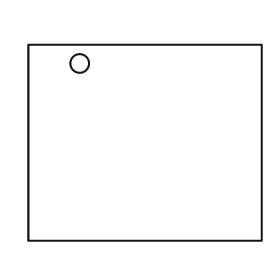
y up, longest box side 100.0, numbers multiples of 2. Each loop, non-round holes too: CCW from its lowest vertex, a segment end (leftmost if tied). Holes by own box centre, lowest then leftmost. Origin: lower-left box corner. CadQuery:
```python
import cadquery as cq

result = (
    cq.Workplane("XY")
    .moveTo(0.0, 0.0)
    .lineTo(100.0, 0.0)
    .lineTo(100.0, 84.0)
    .lineTo(0.0, 84.0)
    .close()
    .moveTo(22.0, 76.0)
    .circle(4.0)
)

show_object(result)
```